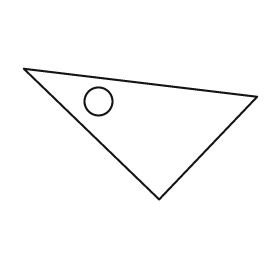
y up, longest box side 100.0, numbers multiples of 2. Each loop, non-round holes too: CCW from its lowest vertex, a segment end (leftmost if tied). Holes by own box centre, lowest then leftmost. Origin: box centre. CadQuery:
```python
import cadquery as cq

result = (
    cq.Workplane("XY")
    .moveTo(8.0, -28.0)
    .lineTo(50.0, 16.0)
    .lineTo(-50.0, 28.0)
    .close()
    .moveTo(-18.0, 14.0)
    .circle(6.0)
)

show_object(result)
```